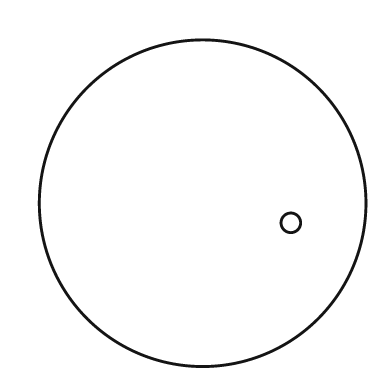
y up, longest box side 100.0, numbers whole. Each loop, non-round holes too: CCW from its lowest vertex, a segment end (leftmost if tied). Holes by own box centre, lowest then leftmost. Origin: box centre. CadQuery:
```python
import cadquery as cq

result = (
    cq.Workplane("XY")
    .moveTo(0.0, 0.0)
    .circle(50.0)
    .moveTo(27.0, -6.0)
    .circle(3.0)
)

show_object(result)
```